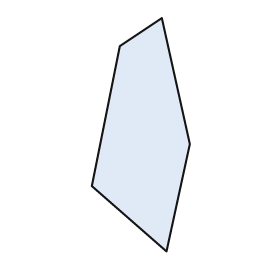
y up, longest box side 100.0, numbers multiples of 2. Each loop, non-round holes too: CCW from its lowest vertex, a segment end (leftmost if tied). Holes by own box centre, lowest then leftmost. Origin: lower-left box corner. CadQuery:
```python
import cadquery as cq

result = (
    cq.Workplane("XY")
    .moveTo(32.0, 0.0)
    .lineTo(42.0, 46.0)
    .lineTo(30.0, 100.0)
    .lineTo(12.0, 88.0)
    .lineTo(0.0, 28.0)
    .close()
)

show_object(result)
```